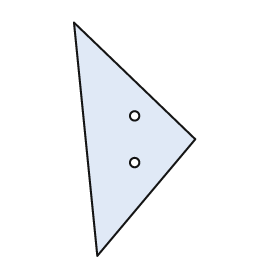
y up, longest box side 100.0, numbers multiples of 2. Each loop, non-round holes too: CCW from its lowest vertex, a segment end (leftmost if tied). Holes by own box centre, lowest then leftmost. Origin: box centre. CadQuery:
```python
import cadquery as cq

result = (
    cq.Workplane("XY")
    .moveTo(-16.0, -50.0)
    .lineTo(26.0, 0.0)
    .lineTo(-26.0, 50.0)
    .close()
    .moveTo(0.0, -10.0)
    .circle(2.0)
    .moveTo(0.0, 10.0)
    .circle(2.0)
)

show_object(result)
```